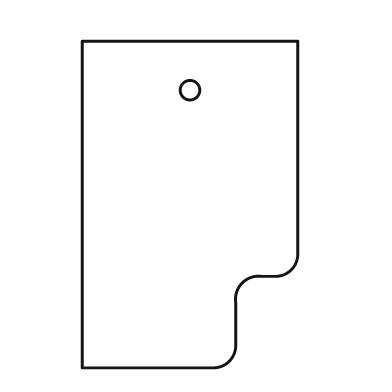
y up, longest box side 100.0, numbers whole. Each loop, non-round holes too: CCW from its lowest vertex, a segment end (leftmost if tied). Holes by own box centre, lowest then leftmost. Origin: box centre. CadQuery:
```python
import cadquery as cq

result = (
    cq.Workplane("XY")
    .moveTo(-33.0, -50.0)
    .lineTo(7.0, -50.0)
    .threePointArc((12.0, -48.0), (14.0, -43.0))
    .lineTo(14.0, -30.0)
    .threePointArc((16.0, -24.0), (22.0, -22.0))
    .lineTo(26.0, -22.0)
    .threePointArc((31.0, -20.0), (33.0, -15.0))
    .lineTo(33.0, 50.0)
    .lineTo(-33.0, 50.0)
    .close()
    .moveTo(0.0, 35.0)
    .circle(3.0)
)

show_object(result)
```